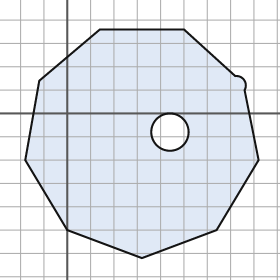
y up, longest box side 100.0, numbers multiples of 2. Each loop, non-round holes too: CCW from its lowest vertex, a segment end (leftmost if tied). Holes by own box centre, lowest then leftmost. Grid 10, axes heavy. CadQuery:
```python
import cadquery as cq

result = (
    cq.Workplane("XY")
    .moveTo(32.0, -62.0)
    .lineTo(64.0, -50.0)
    .lineTo(82.0, -20.0)
    .lineTo(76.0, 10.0)
    .threePointArc((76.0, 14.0), (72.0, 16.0))
    .lineTo(50.0, 36.0)
    .lineTo(14.0, 36.0)
    .lineTo(-12.0, 14.0)
    .lineTo(-18.0, -20.0)
    .lineTo(0.0, -50.0)
    .close()
    .moveTo(44.0, -8.0)
    .circle(8.0)
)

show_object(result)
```